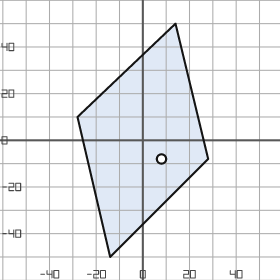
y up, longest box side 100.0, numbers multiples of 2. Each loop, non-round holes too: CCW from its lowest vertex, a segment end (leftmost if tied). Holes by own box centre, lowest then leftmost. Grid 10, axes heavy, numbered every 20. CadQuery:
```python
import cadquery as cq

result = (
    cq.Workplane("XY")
    .moveTo(-14.0, -50.0)
    .lineTo(28.0, -8.0)
    .lineTo(14.0, 50.0)
    .lineTo(-28.0, 10.0)
    .close()
    .moveTo(8.0, -8.0)
    .circle(2.0)
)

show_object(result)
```